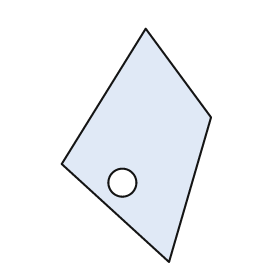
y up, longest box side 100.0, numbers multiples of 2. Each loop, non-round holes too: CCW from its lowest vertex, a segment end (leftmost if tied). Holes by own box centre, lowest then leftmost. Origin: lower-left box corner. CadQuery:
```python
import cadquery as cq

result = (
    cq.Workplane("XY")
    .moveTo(46.0, 0.0)
    .lineTo(64.0, 62.0)
    .lineTo(36.0, 100.0)
    .lineTo(0.0, 42.0)
    .close()
    .moveTo(26.0, 34.0)
    .circle(6.0)
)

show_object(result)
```